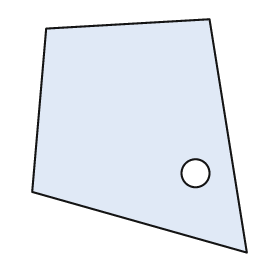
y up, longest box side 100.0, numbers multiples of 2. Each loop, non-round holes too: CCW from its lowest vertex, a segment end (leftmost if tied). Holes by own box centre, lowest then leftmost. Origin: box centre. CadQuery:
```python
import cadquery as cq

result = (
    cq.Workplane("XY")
    .moveTo(46.0, -50.0)
    .lineTo(30.0, 50.0)
    .lineTo(-40.0, 46.0)
    .lineTo(-46.0, -24.0)
    .close()
    .moveTo(24.0, -16.0)
    .circle(6.0)
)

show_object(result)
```